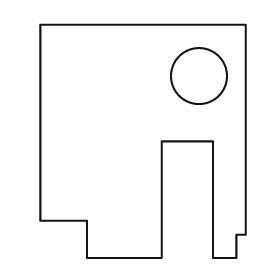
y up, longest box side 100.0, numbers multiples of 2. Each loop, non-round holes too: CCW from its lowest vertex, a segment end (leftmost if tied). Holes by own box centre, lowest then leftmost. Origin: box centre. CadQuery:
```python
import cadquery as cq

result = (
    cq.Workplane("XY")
    .moveTo(-24.0, -50.0)
    .lineTo(8.0, -50.0)
    .lineTo(8.0, 0.0)
    .lineTo(30.0, 0.0)
    .lineTo(30.0, -50.0)
    .lineTo(40.0, -50.0)
    .lineTo(40.0, -40.0)
    .lineTo(44.0, -40.0)
    .lineTo(44.0, 50.0)
    .lineTo(-44.0, 50.0)
    .lineTo(-44.0, -34.0)
    .lineTo(-24.0, -34.0)
    .close()
    .moveTo(24.0, 28.0)
    .circle(12.0)
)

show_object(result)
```